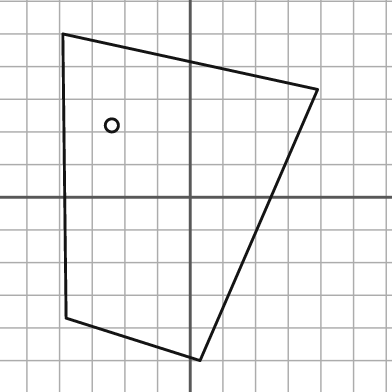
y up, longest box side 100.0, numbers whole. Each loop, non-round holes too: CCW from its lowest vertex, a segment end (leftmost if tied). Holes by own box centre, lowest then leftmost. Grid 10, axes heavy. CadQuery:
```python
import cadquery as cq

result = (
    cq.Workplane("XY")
    .moveTo(3.0, -50.0)
    .lineTo(39.0, 33.0)
    .lineTo(-39.0, 50.0)
    .lineTo(-38.0, -37.0)
    .close()
    .moveTo(-24.0, 22.0)
    .circle(2.0)
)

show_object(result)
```